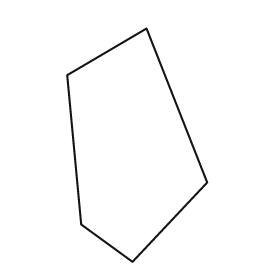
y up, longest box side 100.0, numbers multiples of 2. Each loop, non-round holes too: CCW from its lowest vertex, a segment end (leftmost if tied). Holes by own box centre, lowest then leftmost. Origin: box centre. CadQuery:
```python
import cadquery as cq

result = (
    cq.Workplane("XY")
    .moveTo(-2.0, -50.0)
    .lineTo(30.0, -16.0)
    .lineTo(4.0, 50.0)
    .lineTo(-30.0, 30.0)
    .lineTo(-24.0, -34.0)
    .close()
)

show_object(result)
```